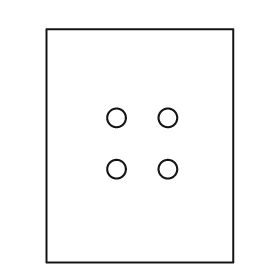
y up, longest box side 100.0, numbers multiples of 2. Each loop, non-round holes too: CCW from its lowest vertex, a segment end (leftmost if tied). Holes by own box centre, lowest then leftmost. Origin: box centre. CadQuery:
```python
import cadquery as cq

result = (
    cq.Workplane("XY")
    .moveTo(-40.0, -50.0)
    .lineTo(40.0, -50.0)
    .lineTo(40.0, 50.0)
    .lineTo(-40.0, 50.0)
    .close()
    .moveTo(-10.0, -10.0)
    .circle(4.0)
    .moveTo(12.0, -10.0)
    .circle(4.0)
    .moveTo(-10.0, 12.0)
    .circle(4.0)
    .moveTo(12.0, 12.0)
    .circle(4.0)
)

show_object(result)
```